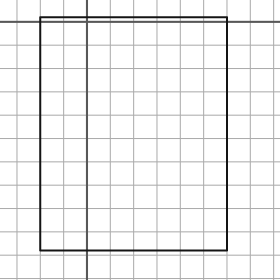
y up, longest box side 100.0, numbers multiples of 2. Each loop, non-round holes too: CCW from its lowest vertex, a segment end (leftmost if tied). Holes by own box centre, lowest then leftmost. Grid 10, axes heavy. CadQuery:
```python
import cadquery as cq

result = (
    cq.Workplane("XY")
    .moveTo(-20.0, -98.0)
    .lineTo(60.0, -98.0)
    .lineTo(60.0, 2.0)
    .lineTo(-20.0, 2.0)
    .close()
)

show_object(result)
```